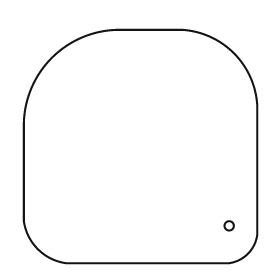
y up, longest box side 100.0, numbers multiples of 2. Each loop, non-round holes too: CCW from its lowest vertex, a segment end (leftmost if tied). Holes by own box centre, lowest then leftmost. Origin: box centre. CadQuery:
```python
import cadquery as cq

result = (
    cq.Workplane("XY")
    .moveTo(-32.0, -50.0)
    .lineTo(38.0, -50.0)
    .threePointArc((46.0, -46.0), (50.0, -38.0))
    .lineTo(50.0, 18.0)
    .threePointArc((40.0, 40.0), (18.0, 50.0))
    .lineTo(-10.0, 50.0)
    .threePointArc((-38.0, 38.0), (-50.0, 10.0))
    .lineTo(-50.0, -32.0)
    .threePointArc((-44.0, -44.0), (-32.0, -50.0))
    .close()
    .moveTo(38.0, -34.0)
    .circle(2.0)
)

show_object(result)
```